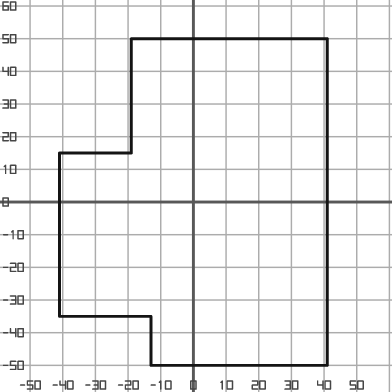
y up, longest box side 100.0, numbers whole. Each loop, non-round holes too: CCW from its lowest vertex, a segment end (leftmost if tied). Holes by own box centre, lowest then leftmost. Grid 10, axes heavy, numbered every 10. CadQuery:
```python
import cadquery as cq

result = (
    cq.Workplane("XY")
    .moveTo(-13.0, -50.0)
    .lineTo(41.0, -50.0)
    .lineTo(41.0, 50.0)
    .lineTo(-19.0, 50.0)
    .lineTo(-19.0, 15.0)
    .lineTo(-41.0, 15.0)
    .lineTo(-41.0, -35.0)
    .lineTo(-13.0, -35.0)
    .close()
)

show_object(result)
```